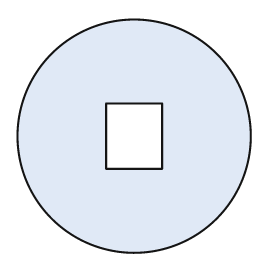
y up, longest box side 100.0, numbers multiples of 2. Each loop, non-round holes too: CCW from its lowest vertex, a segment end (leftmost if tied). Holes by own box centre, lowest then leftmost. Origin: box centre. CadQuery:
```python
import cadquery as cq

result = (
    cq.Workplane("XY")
    .moveTo(0.0, 0.0)
    .circle(50.0)
    .moveTo(-12.0, -14.0)
    .lineTo(12.0, -14.0)
    .lineTo(12.0, 14.0)
    .lineTo(-12.0, 14.0)
    .close()
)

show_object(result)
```